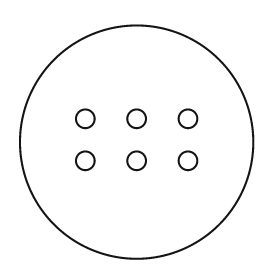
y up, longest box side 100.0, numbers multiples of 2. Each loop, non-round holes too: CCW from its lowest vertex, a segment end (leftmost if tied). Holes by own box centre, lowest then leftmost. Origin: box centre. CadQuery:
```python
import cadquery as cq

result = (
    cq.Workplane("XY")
    .moveTo(0.0, 0.0)
    .circle(50.0)
    .moveTo(-22.0, -8.0)
    .circle(4.0)
    .moveTo(0.0, -8.0)
    .circle(4.0)
    .moveTo(22.0, -8.0)
    .circle(4.0)
    .moveTo(-22.0, 10.0)
    .circle(4.0)
    .moveTo(0.0, 10.0)
    .circle(4.0)
    .moveTo(22.0, 10.0)
    .circle(4.0)
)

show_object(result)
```